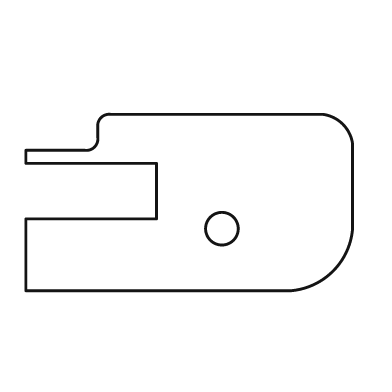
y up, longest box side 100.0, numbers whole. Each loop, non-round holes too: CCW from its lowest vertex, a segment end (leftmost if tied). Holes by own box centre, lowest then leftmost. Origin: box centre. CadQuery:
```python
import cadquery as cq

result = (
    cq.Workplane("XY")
    .moveTo(-50.0, -27.0)
    .lineTo(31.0, -27.0)
    .threePointArc((44.0, -21.0), (50.0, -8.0))
    .lineTo(50.0, 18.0)
    .threePointArc((47.0, 24.0), (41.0, 27.0))
    .lineTo(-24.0, 27.0)
    .threePointArc((-27.0, 26.0), (-28.0, 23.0))
    .lineTo(-28.0, 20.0)
    .threePointArc((-29.0, 17.0), (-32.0, 16.0))
    .lineTo(-50.0, 16.0)
    .lineTo(-50.0, 12.0)
    .lineTo(-10.0, 12.0)
    .lineTo(-10.0, -5.0)
    .lineTo(-50.0, -5.0)
    .close()
    .moveTo(10.0, -8.0)
    .circle(5.0)
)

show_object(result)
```